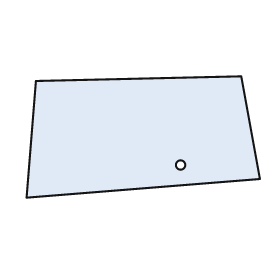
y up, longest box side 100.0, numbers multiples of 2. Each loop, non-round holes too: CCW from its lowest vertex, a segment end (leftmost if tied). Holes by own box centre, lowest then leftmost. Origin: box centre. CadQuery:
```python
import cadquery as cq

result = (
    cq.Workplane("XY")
    .moveTo(-50.0, -26.0)
    .lineTo(50.0, -18.0)
    .lineTo(42.0, 26.0)
    .lineTo(-46.0, 24.0)
    .close()
    .moveTo(16.0, -12.0)
    .circle(2.0)
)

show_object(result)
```